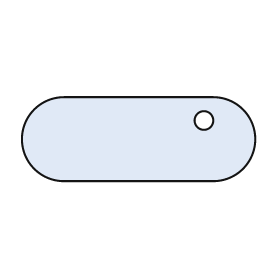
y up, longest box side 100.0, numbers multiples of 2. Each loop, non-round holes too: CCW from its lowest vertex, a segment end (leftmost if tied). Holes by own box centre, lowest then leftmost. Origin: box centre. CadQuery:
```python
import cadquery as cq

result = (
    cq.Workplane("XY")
    .moveTo(-32.0, -18.0)
    .lineTo(32.0, -18.0)
    .threePointArc((50.0, 0.0), (32.0, 18.0))
    .lineTo(-32.0, 18.0)
    .threePointArc((-50.0, 0.0), (-32.0, -18.0))
    .close()
    .moveTo(28.0, 8.0)
    .circle(4.0)
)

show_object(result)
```